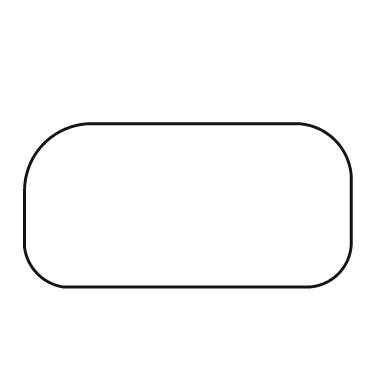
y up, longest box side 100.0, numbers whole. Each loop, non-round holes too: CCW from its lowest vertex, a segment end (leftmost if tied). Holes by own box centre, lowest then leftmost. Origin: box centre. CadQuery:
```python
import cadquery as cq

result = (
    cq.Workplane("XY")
    .moveTo(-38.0, -25.0)
    .lineTo(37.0, -25.0)
    .threePointArc((46.0, -21.0), (50.0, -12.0))
    .lineTo(50.0, 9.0)
    .threePointArc((45.0, 20.0), (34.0, 25.0))
    .lineTo(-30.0, 25.0)
    .threePointArc((-44.0, 19.0), (-50.0, 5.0))
    .lineTo(-50.0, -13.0)
    .threePointArc((-46.0, -21.0), (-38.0, -25.0))
    .close()
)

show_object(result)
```